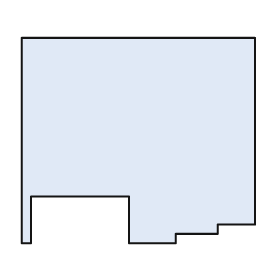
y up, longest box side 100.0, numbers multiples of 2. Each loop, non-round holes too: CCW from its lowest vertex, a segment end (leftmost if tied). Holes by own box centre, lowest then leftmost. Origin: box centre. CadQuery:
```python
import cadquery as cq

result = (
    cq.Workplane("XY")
    .moveTo(-50.0, -44.0)
    .lineTo(-46.0, -44.0)
    .lineTo(-46.0, -24.0)
    .lineTo(-4.0, -24.0)
    .lineTo(-4.0, -44.0)
    .lineTo(16.0, -44.0)
    .lineTo(16.0, -40.0)
    .lineTo(34.0, -40.0)
    .lineTo(34.0, -36.0)
    .lineTo(50.0, -36.0)
    .lineTo(50.0, 44.0)
    .lineTo(-50.0, 44.0)
    .close()
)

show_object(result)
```